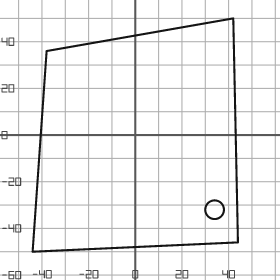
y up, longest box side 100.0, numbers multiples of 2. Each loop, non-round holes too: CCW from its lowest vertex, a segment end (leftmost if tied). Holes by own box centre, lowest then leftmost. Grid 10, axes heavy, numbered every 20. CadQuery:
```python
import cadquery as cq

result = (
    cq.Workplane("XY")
    .moveTo(-44.0, -50.0)
    .lineTo(44.0, -46.0)
    .lineTo(42.0, 50.0)
    .lineTo(-38.0, 36.0)
    .close()
    .moveTo(34.0, -32.0)
    .circle(4.0)
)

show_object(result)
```